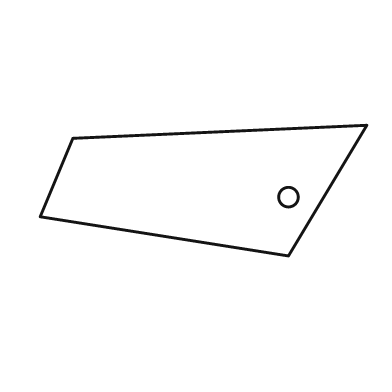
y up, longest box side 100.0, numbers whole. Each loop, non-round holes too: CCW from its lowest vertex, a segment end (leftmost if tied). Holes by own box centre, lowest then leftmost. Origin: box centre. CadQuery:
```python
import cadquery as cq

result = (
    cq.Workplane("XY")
    .moveTo(26.0, -20.0)
    .lineTo(50.0, 20.0)
    .lineTo(-40.0, 16.0)
    .lineTo(-50.0, -8.0)
    .close()
    .moveTo(26.0, -2.0)
    .circle(3.0)
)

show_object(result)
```